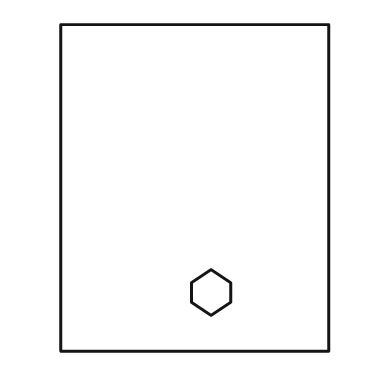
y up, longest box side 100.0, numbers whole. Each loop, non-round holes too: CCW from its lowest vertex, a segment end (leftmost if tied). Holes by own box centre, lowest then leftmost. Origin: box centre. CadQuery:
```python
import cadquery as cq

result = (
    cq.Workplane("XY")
    .moveTo(-41.0, -50.0)
    .lineTo(41.0, -50.0)
    .lineTo(41.0, 50.0)
    .lineTo(-41.0, 50.0)
    .close()
    .moveTo(5.0, -39.0)
    .lineTo(11.0, -35.0)
    .lineTo(11.0, -29.0)
    .lineTo(5.0, -25.0)
    .lineTo(-1.0, -29.0)
    .lineTo(-1.0, -35.0)
    .close()
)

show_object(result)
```